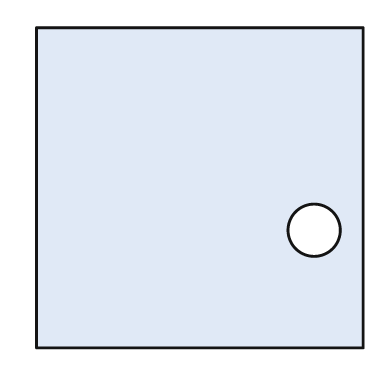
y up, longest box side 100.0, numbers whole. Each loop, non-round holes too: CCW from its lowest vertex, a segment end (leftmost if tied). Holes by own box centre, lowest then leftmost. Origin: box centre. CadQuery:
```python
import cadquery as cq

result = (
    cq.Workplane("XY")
    .moveTo(-50.0, -49.0)
    .lineTo(50.0, -49.0)
    .lineTo(50.0, 49.0)
    .lineTo(-50.0, 49.0)
    .close()
    .moveTo(35.0, -13.0)
    .circle(8.0)
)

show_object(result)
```